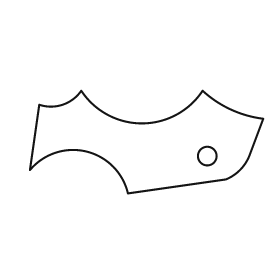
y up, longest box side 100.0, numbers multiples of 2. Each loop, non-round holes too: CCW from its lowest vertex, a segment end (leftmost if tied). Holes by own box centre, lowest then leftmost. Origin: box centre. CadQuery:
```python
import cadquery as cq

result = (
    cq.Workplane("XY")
    .moveTo(-8.0, -22.0)
    .lineTo(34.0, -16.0)
    .threePointArc((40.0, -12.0), (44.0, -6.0))
    .lineTo(50.0, 10.0)
    .threePointArc((36.0, 14.0), (24.0, 22.0))
    .threePointArc((-2.0, 8.0), (-28.0, 22.0))
    .threePointArc((-36.0, 16.0), (-46.0, 16.0))
    .lineTo(-50.0, -12.0)
    .threePointArc((-26.0, -4.0), (-8.0, -22.0))
    .close()
    .moveTo(26.0, -6.0)
    .circle(4.0)
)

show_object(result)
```